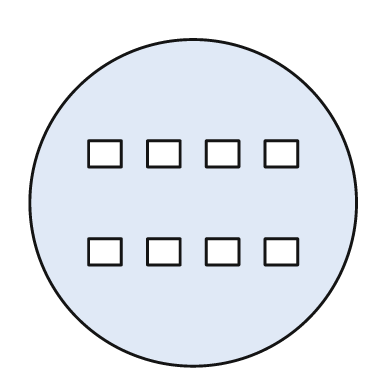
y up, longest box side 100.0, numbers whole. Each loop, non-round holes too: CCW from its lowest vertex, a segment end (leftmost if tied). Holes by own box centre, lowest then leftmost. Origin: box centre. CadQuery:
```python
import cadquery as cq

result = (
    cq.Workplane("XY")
    .moveTo(0.0, 0.0)
    .circle(50.0)
    .moveTo(-32.0, -19.0)
    .lineTo(-22.0, -19.0)
    .lineTo(-22.0, -11.0)
    .lineTo(-32.0, -11.0)
    .close()
    .moveTo(-14.0, -19.0)
    .lineTo(-4.0, -19.0)
    .lineTo(-4.0, -11.0)
    .lineTo(-14.0, -11.0)
    .close()
    .moveTo(4.0, -19.0)
    .lineTo(14.0, -19.0)
    .lineTo(14.0, -11.0)
    .lineTo(4.0, -11.0)
    .close()
    .moveTo(22.0, -19.0)
    .lineTo(32.0, -19.0)
    .lineTo(32.0, -11.0)
    .lineTo(22.0, -11.0)
    .close()
    .moveTo(-32.0, 11.0)
    .lineTo(-22.0, 11.0)
    .lineTo(-22.0, 19.0)
    .lineTo(-32.0, 19.0)
    .close()
    .moveTo(-14.0, 11.0)
    .lineTo(-4.0, 11.0)
    .lineTo(-4.0, 19.0)
    .lineTo(-14.0, 19.0)
    .close()
    .moveTo(4.0, 11.0)
    .lineTo(14.0, 11.0)
    .lineTo(14.0, 19.0)
    .lineTo(4.0, 19.0)
    .close()
    .moveTo(22.0, 11.0)
    .lineTo(32.0, 11.0)
    .lineTo(32.0, 19.0)
    .lineTo(22.0, 19.0)
    .close()
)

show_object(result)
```